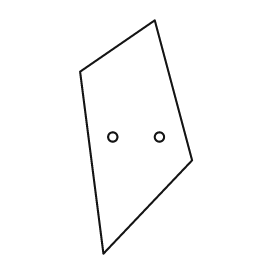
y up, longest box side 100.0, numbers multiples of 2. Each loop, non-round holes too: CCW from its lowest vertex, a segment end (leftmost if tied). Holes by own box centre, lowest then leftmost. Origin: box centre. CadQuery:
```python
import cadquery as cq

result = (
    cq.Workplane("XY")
    .moveTo(-14.0, -50.0)
    .lineTo(24.0, -10.0)
    .lineTo(8.0, 50.0)
    .lineTo(-24.0, 28.0)
    .close()
    .moveTo(-10.0, 0.0)
    .circle(2.0)
    .moveTo(10.0, 0.0)
    .circle(2.0)
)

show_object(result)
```